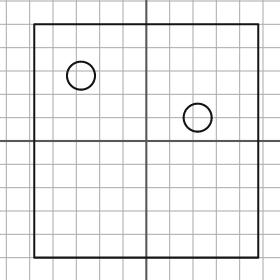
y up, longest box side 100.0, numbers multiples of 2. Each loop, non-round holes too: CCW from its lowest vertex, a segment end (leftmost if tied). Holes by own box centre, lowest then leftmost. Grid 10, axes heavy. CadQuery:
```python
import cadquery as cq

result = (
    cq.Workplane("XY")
    .moveTo(-48.0, -50.0)
    .lineTo(48.0, -50.0)
    .lineTo(48.0, 50.0)
    .lineTo(-48.0, 50.0)
    .close()
    .moveTo(22.0, 10.0)
    .circle(6.0)
    .moveTo(-28.0, 28.0)
    .circle(6.0)
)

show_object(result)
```